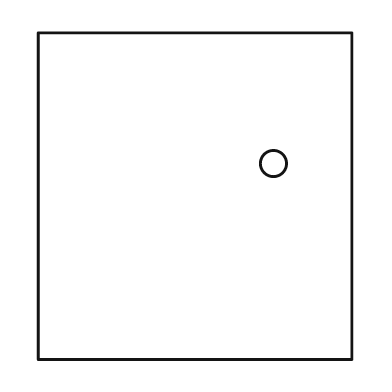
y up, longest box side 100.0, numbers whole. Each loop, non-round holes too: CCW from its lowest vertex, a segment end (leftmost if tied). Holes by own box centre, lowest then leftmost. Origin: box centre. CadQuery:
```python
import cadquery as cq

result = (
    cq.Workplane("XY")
    .moveTo(-48.0, -50.0)
    .lineTo(48.0, -50.0)
    .lineTo(48.0, 50.0)
    .lineTo(-48.0, 50.0)
    .close()
    .moveTo(24.0, 10.0)
    .circle(4.0)
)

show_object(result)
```